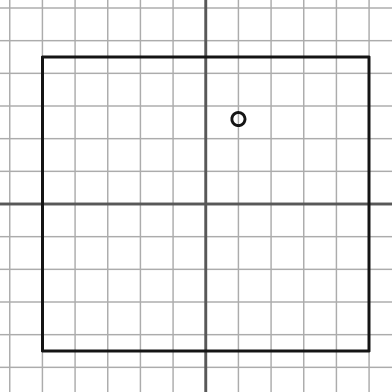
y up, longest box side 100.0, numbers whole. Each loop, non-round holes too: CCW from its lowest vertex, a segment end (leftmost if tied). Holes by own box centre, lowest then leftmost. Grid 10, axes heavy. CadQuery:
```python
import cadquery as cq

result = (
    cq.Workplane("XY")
    .moveTo(-50.0, -45.0)
    .lineTo(50.0, -45.0)
    .lineTo(50.0, 45.0)
    .lineTo(-50.0, 45.0)
    .close()
    .moveTo(10.0, 26.0)
    .circle(2.0)
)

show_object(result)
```